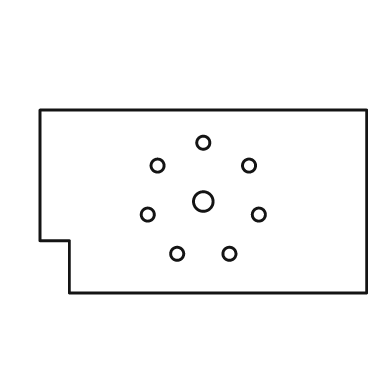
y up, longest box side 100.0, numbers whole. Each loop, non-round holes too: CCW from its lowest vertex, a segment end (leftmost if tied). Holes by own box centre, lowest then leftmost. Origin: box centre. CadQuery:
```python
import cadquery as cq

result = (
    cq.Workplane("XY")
    .moveTo(-41.0, -28.0)
    .lineTo(50.0, -28.0)
    .lineTo(50.0, 28.0)
    .lineTo(-50.0, 28.0)
    .lineTo(-50.0, -12.0)
    .lineTo(-41.0, -12.0)
    .close()
    .moveTo(-8.0, -16.0)
    .circle(2.0)
    .moveTo(8.0, -16.0)
    .circle(2.0)
    .moveTo(-17.0, -4.0)
    .circle(2.0)
    .moveTo(17.0, -4.0)
    .circle(2.0)
    .moveTo(0.0, 0.0)
    .circle(3.0)
    .moveTo(-14.0, 11.0)
    .circle(2.0)
    .moveTo(14.0, 11.0)
    .circle(2.0)
    .moveTo(0.0, 18.0)
    .circle(2.0)
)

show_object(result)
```